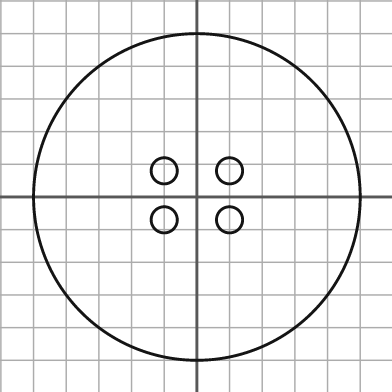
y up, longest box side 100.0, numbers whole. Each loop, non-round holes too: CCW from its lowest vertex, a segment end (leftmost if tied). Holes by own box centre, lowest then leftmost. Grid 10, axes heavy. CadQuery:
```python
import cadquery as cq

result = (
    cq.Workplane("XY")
    .moveTo(0.0, 0.0)
    .circle(50.0)
    .moveTo(-10.0, -7.0)
    .circle(4.0)
    .moveTo(10.0, -7.0)
    .circle(4.0)
    .moveTo(-10.0, 8.0)
    .circle(4.0)
    .moveTo(10.0, 8.0)
    .circle(4.0)
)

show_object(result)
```